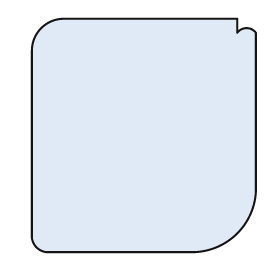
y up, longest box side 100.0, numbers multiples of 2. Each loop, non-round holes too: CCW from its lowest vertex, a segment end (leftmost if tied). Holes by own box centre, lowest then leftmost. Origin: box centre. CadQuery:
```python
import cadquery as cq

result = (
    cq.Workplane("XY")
    .moveTo(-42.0, -50.0)
    .lineTo(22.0, -50.0)
    .threePointArc((40.0, -42.0), (48.0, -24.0))
    .lineTo(48.0, 44.0)
    .threePointArc((44.0, 46.0), (40.0, 44.0))
    .lineTo(40.0, 50.0)
    .lineTo(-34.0, 50.0)
    .threePointArc((-44.0, 46.0), (-48.0, 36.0))
    .lineTo(-48.0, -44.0)
    .threePointArc((-46.0, -48.0), (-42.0, -50.0))
    .close()
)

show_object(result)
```